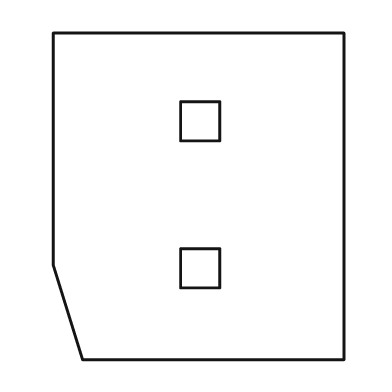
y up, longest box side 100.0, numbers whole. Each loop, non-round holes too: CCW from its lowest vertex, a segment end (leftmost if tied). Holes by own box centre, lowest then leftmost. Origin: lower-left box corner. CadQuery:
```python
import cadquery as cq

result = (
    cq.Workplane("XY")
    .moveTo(9.0, 0.0)
    .lineTo(89.0, 0.0)
    .lineTo(89.0, 100.0)
    .lineTo(0.0, 100.0)
    .lineTo(0.0, 29.0)
    .close()
    .moveTo(39.0, 22.0)
    .lineTo(51.0, 22.0)
    .lineTo(51.0, 34.0)
    .lineTo(39.0, 34.0)
    .close()
    .moveTo(39.0, 67.0)
    .lineTo(51.0, 67.0)
    .lineTo(51.0, 79.0)
    .lineTo(39.0, 79.0)
    .close()
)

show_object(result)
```